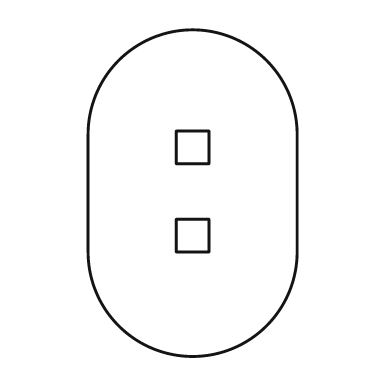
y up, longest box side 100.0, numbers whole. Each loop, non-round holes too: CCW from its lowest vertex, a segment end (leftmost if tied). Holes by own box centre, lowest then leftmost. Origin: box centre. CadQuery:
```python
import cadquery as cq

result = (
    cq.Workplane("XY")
    .moveTo(-32.0, -18.0)
    .threePointArc((0.0, -50.0), (32.0, -18.0))
    .lineTo(32.0, 18.0)
    .threePointArc((0.0, 50.0), (-32.0, 18.0))
    .close()
    .moveTo(-5.0, -18.0)
    .lineTo(5.0, -18.0)
    .lineTo(5.0, -8.0)
    .lineTo(-5.0, -8.0)
    .close()
    .moveTo(-5.0, 9.0)
    .lineTo(5.0, 9.0)
    .lineTo(5.0, 19.0)
    .lineTo(-5.0, 19.0)
    .close()
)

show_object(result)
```